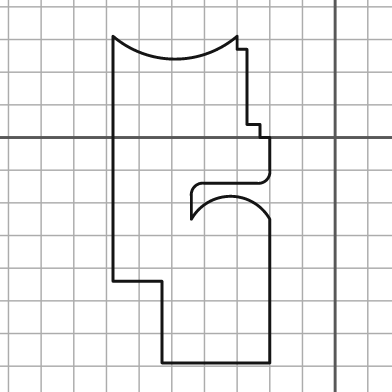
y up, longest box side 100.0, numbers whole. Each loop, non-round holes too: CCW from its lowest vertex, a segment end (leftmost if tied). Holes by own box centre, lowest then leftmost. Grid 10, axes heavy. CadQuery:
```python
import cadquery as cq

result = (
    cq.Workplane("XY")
    .moveTo(-53.0, -69.0)
    .lineTo(-20.0, -69.0)
    .lineTo(-20.0, -25.0)
    .threePointArc((-32.0, -18.0), (-44.0, -25.0))
    .lineTo(-44.0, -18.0)
    .threePointArc((-43.0, -15.0), (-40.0, -14.0))
    .lineTo(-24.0, -14.0)
    .threePointArc((-21.0, -13.0), (-20.0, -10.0))
    .lineTo(-20.0, 0.0)
    .lineTo(-23.0, 0.0)
    .lineTo(-23.0, 4.0)
    .lineTo(-27.0, 4.0)
    .lineTo(-27.0, 27.0)
    .lineTo(-30.0, 27.0)
    .lineTo(-30.0, 31.0)
    .threePointArc((-49.0, 24.0), (-68.0, 31.0))
    .lineTo(-68.0, -44.0)
    .lineTo(-53.0, -44.0)
    .close()
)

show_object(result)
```